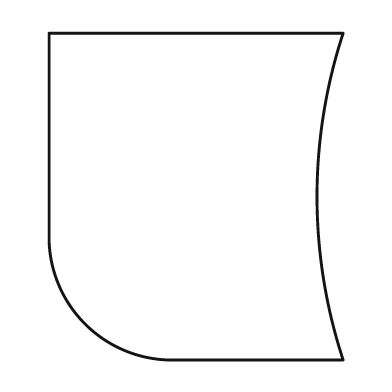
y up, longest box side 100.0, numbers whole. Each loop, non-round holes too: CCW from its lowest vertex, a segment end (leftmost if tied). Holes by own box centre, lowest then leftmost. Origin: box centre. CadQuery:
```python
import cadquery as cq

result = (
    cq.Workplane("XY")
    .moveTo(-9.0, -50.0)
    .lineTo(45.0, -50.0)
    .threePointArc((37.0, 0.0), (45.0, 50.0))
    .lineTo(-45.0, 50.0)
    .lineTo(-45.0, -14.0)
    .threePointArc((-34.0, -39.0), (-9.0, -50.0))
    .close()
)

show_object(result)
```